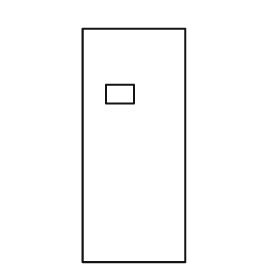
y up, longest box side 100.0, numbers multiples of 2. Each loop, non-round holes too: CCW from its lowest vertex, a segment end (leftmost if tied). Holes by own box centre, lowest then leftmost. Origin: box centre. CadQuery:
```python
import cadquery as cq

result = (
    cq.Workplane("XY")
    .moveTo(-22.0, -50.0)
    .lineTo(22.0, -50.0)
    .lineTo(22.0, 50.0)
    .lineTo(-22.0, 50.0)
    .close()
    .moveTo(-12.0, 18.0)
    .lineTo(0.0, 18.0)
    .lineTo(0.0, 26.0)
    .lineTo(-12.0, 26.0)
    .close()
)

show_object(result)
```